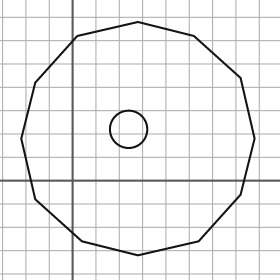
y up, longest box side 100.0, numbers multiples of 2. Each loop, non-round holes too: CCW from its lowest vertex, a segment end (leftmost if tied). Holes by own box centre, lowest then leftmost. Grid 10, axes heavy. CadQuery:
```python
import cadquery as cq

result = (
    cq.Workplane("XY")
    .moveTo(28.0, -32.0)
    .lineTo(54.0, -26.0)
    .lineTo(72.0, -6.0)
    .lineTo(78.0, 18.0)
    .lineTo(72.0, 44.0)
    .lineTo(52.0, 62.0)
    .lineTo(28.0, 68.0)
    .lineTo(2.0, 62.0)
    .lineTo(-16.0, 42.0)
    .lineTo(-22.0, 18.0)
    .lineTo(-16.0, -8.0)
    .lineTo(4.0, -26.0)
    .close()
    .moveTo(24.0, 22.0)
    .circle(8.0)
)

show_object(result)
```